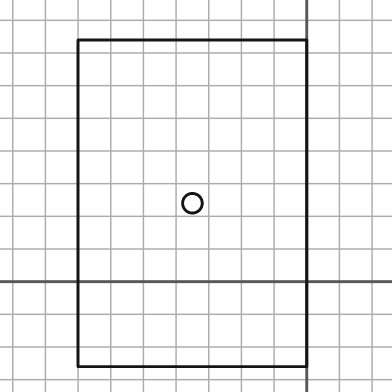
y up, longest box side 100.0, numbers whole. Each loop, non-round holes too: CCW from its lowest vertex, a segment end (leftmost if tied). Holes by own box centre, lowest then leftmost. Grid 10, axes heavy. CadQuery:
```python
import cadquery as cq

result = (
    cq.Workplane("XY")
    .moveTo(-70.0, -26.0)
    .lineTo(0.0, -26.0)
    .lineTo(0.0, 74.0)
    .lineTo(-70.0, 74.0)
    .close()
    .moveTo(-35.0, 24.0)
    .circle(3.0)
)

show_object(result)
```